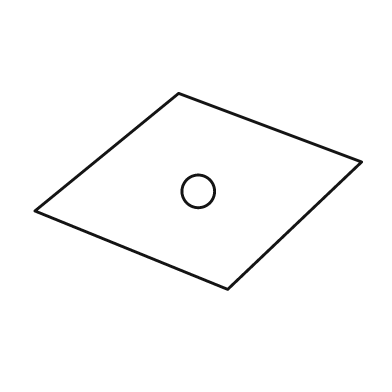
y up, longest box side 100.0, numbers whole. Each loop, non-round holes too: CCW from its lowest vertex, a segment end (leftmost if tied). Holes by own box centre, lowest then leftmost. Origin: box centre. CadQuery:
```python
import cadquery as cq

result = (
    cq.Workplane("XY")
    .moveTo(9.0, -30.0)
    .lineTo(50.0, 9.0)
    .lineTo(-6.0, 30.0)
    .lineTo(-50.0, -6.0)
    .close()
    .moveTo(0.0, 0.0)
    .circle(5.0)
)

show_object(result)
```